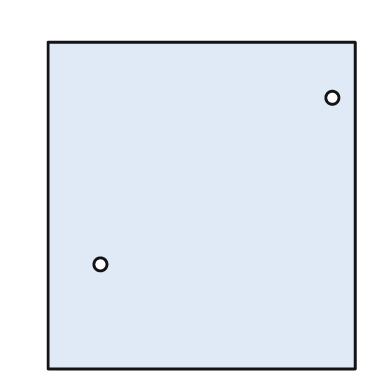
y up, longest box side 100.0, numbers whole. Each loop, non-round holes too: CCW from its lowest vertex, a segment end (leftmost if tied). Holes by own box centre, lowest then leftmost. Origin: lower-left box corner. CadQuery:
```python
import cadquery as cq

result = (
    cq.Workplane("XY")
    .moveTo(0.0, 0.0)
    .lineTo(94.0, 0.0)
    .lineTo(94.0, 100.0)
    .lineTo(0.0, 100.0)
    .close()
    .moveTo(16.0, 32.0)
    .circle(2.0)
    .moveTo(87.0, 83.0)
    .circle(2.0)
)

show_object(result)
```